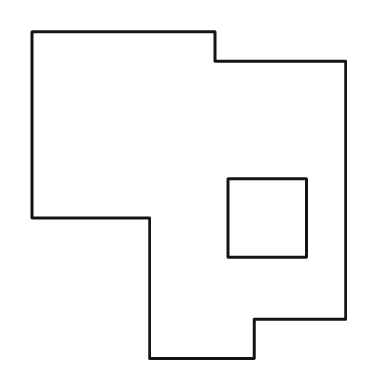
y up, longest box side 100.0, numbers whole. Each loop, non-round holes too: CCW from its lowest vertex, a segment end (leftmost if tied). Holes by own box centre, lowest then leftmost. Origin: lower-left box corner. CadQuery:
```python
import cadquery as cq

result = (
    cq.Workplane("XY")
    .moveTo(36.0, 0.0)
    .lineTo(68.0, 0.0)
    .lineTo(68.0, 12.0)
    .lineTo(96.0, 12.0)
    .lineTo(96.0, 91.0)
    .lineTo(56.0, 91.0)
    .lineTo(56.0, 100.0)
    .lineTo(0.0, 100.0)
    .lineTo(0.0, 43.0)
    .lineTo(36.0, 43.0)
    .close()
    .moveTo(60.0, 31.0)
    .lineTo(84.0, 31.0)
    .lineTo(84.0, 55.0)
    .lineTo(60.0, 55.0)
    .close()
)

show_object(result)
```